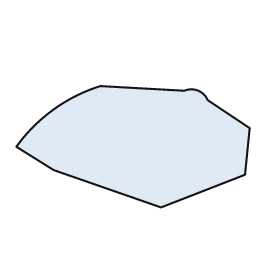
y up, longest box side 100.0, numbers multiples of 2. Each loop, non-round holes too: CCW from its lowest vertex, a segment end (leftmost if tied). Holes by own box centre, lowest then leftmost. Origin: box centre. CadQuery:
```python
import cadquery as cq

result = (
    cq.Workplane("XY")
    .moveTo(12.0, -26.0)
    .lineTo(48.0, -12.0)
    .lineTo(50.0, 8.0)
    .lineTo(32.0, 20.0)
    .threePointArc((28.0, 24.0), (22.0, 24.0))
    .lineTo(-14.0, 26.0)
    .threePointArc((-34.0, 16.0), (-50.0, 0.0))
    .lineTo(-34.0, -10.0)
    .close()
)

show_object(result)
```